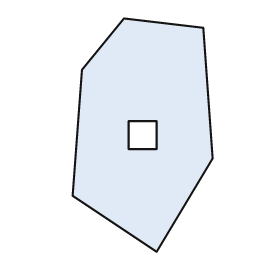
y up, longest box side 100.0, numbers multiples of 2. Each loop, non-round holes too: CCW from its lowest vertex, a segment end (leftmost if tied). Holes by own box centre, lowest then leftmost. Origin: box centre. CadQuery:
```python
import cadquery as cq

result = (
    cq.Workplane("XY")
    .moveTo(6.0, -50.0)
    .lineTo(30.0, -10.0)
    .lineTo(26.0, 46.0)
    .lineTo(-8.0, 50.0)
    .lineTo(-26.0, 28.0)
    .lineTo(-30.0, -26.0)
    .close()
    .moveTo(-6.0, -6.0)
    .lineTo(6.0, -6.0)
    .lineTo(6.0, 6.0)
    .lineTo(-6.0, 6.0)
    .close()
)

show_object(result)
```